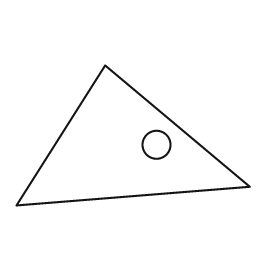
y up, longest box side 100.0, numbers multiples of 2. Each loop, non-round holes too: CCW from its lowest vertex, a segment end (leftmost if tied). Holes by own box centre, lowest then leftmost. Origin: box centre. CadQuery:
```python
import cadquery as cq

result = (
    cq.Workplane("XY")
    .moveTo(-50.0, -30.0)
    .lineTo(50.0, -22.0)
    .lineTo(-12.0, 30.0)
    .close()
    .moveTo(10.0, -4.0)
    .circle(6.0)
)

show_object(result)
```